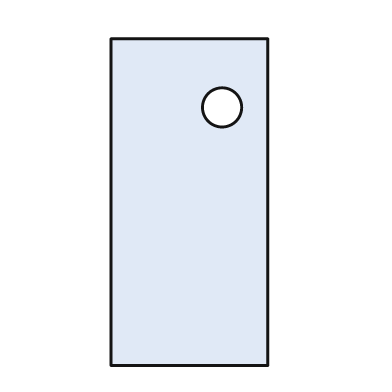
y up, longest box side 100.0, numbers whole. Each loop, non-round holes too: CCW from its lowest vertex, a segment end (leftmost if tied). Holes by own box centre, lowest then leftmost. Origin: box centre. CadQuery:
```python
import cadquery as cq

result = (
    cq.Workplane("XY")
    .moveTo(-24.0, -50.0)
    .lineTo(24.0, -50.0)
    .lineTo(24.0, 50.0)
    .lineTo(-24.0, 50.0)
    .close()
    .moveTo(10.0, 29.0)
    .circle(6.0)
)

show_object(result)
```